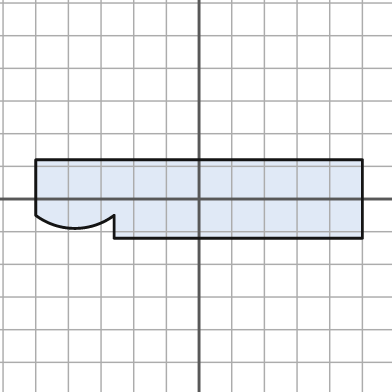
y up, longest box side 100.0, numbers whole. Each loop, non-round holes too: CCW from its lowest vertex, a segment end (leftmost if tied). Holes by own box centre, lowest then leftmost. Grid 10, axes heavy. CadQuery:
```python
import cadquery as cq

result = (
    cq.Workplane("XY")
    .moveTo(-26.0, -12.0)
    .lineTo(50.0, -12.0)
    .lineTo(50.0, 12.0)
    .lineTo(-50.0, 12.0)
    .lineTo(-50.0, -5.0)
    .threePointArc((-38.0, -9.0), (-26.0, -5.0))
    .close()
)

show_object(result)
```